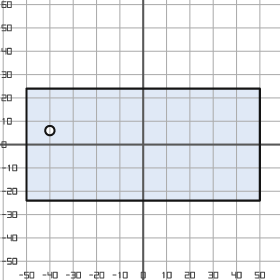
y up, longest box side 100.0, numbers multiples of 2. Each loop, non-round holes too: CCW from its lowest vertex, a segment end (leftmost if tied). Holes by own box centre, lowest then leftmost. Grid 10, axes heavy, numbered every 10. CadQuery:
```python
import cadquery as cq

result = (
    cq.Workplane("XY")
    .moveTo(-50.0, -24.0)
    .lineTo(50.0, -24.0)
    .lineTo(50.0, 24.0)
    .lineTo(-50.0, 24.0)
    .close()
    .moveTo(-40.0, 6.0)
    .circle(2.0)
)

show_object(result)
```